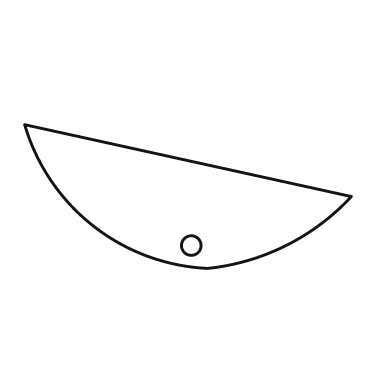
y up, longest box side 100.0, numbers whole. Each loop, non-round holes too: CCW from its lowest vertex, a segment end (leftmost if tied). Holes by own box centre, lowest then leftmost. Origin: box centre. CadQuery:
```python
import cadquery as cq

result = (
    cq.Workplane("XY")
    .moveTo(6.0, -22.0)
    .threePointArc((30.0, -15.0), (50.0, 0.0))
    .lineTo(-50.0, 22.0)
    .threePointArc((-29.0, -9.0), (6.0, -22.0))
    .close()
    .moveTo(1.0, -15.0)
    .circle(3.0)
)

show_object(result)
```